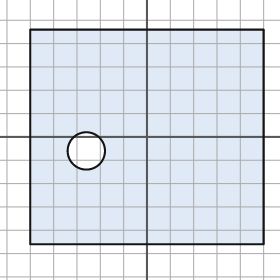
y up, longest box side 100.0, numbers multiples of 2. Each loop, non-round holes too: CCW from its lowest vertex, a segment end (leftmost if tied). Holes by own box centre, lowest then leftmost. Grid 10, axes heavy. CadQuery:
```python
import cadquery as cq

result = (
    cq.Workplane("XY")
    .moveTo(-50.0, -46.0)
    .lineTo(50.0, -46.0)
    .lineTo(50.0, 46.0)
    .lineTo(-50.0, 46.0)
    .close()
    .moveTo(-26.0, -6.0)
    .circle(8.0)
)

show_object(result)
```